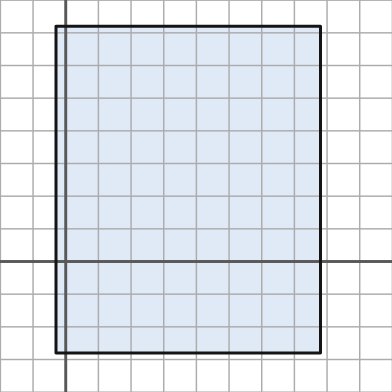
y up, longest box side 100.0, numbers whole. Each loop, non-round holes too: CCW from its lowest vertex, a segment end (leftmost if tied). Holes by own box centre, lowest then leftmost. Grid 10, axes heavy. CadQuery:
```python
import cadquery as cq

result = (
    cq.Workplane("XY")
    .moveTo(-3.0, -28.0)
    .lineTo(78.0, -28.0)
    .lineTo(78.0, 72.0)
    .lineTo(-3.0, 72.0)
    .close()
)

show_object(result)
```